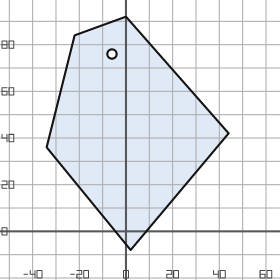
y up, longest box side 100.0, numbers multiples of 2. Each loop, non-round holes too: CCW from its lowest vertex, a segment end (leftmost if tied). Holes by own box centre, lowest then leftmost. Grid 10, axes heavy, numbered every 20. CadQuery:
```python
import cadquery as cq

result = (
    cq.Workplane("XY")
    .moveTo(2.0, -8.0)
    .lineTo(44.0, 42.0)
    .lineTo(0.0, 92.0)
    .lineTo(-22.0, 84.0)
    .lineTo(-34.0, 36.0)
    .close()
    .moveTo(-6.0, 76.0)
    .circle(2.0)
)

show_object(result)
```